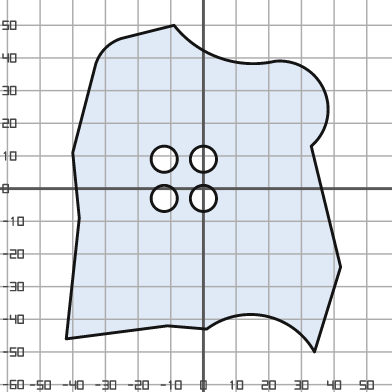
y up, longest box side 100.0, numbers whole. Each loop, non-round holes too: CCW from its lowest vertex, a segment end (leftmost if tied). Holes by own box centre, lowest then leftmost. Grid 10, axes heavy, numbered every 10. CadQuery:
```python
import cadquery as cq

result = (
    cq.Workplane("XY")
    .moveTo(34.0, -50.0)
    .lineTo(42.0, -24.0)
    .lineTo(33.0, 13.0)
    .threePointArc((37.0, 30.0), (22.0, 39.0))
    .threePointArc((5.0, 40.0), (-9.0, 50.0))
    .lineTo(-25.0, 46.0)
    .threePointArc((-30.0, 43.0), (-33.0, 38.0))
    .lineTo(-40.0, 11.0)
    .lineTo(-38.0, -9.0)
    .lineTo(-42.0, -46.0)
    .lineTo(-11.0, -42.0)
    .lineTo(1.0, -43.0)
    .threePointArc((19.0, -39.0), (34.0, -50.0))
    .close()
    .moveTo(-12.0, -3.0)
    .circle(4.0)
    .moveTo(0.0, -3.0)
    .circle(4.0)
    .moveTo(-12.0, 9.0)
    .circle(4.0)
    .moveTo(0.0, 9.0)
    .circle(4.0)
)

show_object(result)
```